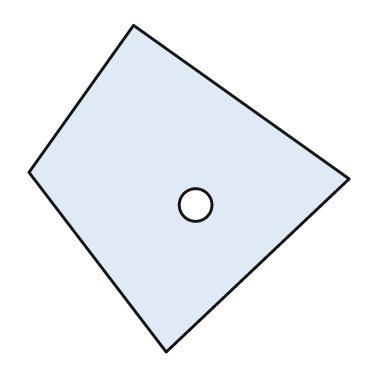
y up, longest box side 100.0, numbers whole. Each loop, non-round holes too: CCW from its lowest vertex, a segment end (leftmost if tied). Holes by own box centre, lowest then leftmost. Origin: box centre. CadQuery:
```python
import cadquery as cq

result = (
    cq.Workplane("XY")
    .moveTo(-7.0, -50.0)
    .lineTo(49.0, 3.0)
    .lineTo(-17.0, 50.0)
    .lineTo(-49.0, 5.0)
    .close()
    .moveTo(2.0, -5.0)
    .circle(5.0)
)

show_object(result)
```